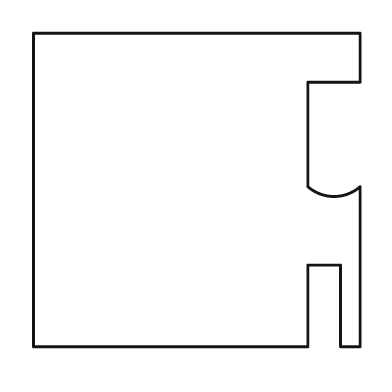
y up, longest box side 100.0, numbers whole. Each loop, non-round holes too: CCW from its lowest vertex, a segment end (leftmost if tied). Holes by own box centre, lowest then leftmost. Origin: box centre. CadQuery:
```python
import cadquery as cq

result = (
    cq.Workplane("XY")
    .moveTo(-50.0, -48.0)
    .lineTo(34.0, -48.0)
    .lineTo(34.0, -23.0)
    .lineTo(44.0, -23.0)
    .lineTo(44.0, -48.0)
    .lineTo(50.0, -48.0)
    .lineTo(50.0, 1.0)
    .threePointArc((42.0, -2.0), (34.0, 1.0))
    .lineTo(34.0, 33.0)
    .lineTo(50.0, 33.0)
    .lineTo(50.0, 48.0)
    .lineTo(-50.0, 48.0)
    .close()
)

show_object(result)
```